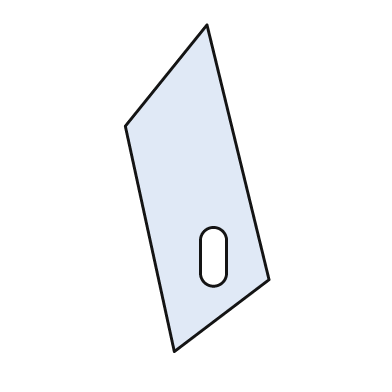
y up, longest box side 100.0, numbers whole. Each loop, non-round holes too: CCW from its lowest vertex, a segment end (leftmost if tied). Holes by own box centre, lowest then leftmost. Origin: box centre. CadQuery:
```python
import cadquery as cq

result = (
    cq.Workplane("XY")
    .moveTo(-7.0, -50.0)
    .lineTo(22.0, -28.0)
    .lineTo(3.0, 50.0)
    .lineTo(-22.0, 19.0)
    .close()
    .moveTo(1.0, -26.0)
    .threePointArc((5.0, -30.0), (9.0, -26.0))
    .lineTo(9.0, -16.0)
    .threePointArc((5.0, -12.0), (1.0, -16.0))
    .close()
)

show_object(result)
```